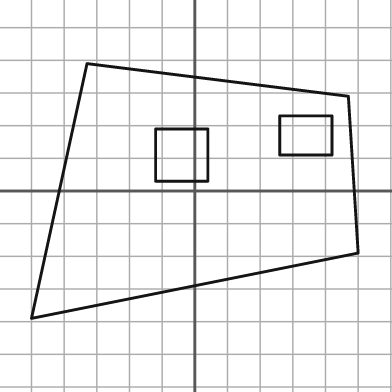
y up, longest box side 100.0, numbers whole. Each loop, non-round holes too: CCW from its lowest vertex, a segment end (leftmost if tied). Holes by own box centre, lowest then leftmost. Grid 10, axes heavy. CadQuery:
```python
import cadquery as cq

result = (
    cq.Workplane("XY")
    .moveTo(-50.0, -39.0)
    .lineTo(50.0, -19.0)
    .lineTo(47.0, 29.0)
    .lineTo(-33.0, 39.0)
    .close()
    .moveTo(-12.0, 3.0)
    .lineTo(4.0, 3.0)
    .lineTo(4.0, 19.0)
    .lineTo(-12.0, 19.0)
    .close()
    .moveTo(26.0, 11.0)
    .lineTo(42.0, 11.0)
    .lineTo(42.0, 23.0)
    .lineTo(26.0, 23.0)
    .close()
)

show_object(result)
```